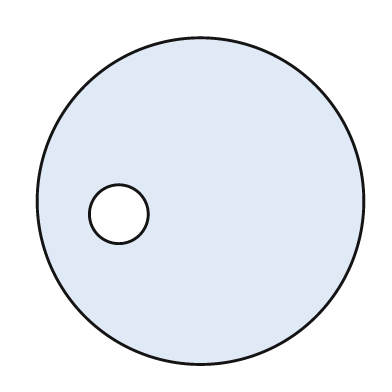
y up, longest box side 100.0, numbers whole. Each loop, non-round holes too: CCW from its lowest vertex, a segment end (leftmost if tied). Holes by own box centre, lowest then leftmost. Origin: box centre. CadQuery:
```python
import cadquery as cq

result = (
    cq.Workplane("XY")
    .moveTo(0.0, 0.0)
    .circle(50.0)
    .moveTo(-25.0, -4.0)
    .circle(9.0)
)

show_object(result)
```